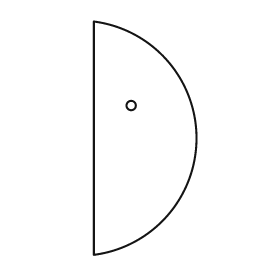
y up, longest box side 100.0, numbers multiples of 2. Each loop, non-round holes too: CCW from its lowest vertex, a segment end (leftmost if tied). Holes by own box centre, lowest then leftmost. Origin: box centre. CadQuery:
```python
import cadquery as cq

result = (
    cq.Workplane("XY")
    .moveTo(-22.0, -50.0)
    .threePointArc((22.0, 0.0), (-22.0, 50.0))
    .close()
    .moveTo(-6.0, 14.0)
    .circle(2.0)
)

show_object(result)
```